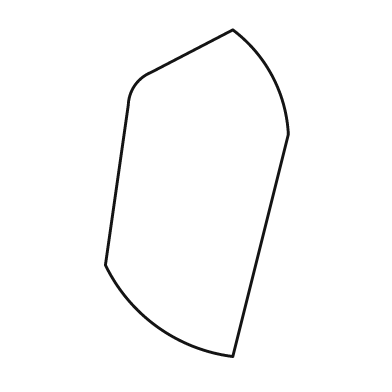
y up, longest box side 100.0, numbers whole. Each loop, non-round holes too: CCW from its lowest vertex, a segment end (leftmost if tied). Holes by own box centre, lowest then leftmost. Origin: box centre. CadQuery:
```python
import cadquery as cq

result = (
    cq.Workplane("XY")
    .moveTo(11.0, -50.0)
    .lineTo(28.0, 18.0)
    .threePointArc((23.0, 36.0), (11.0, 50.0))
    .lineTo(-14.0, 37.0)
    .threePointArc((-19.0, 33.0), (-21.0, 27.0))
    .lineTo(-28.0, -22.0)
    .threePointArc((-12.0, -41.0), (11.0, -50.0))
    .close()
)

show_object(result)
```